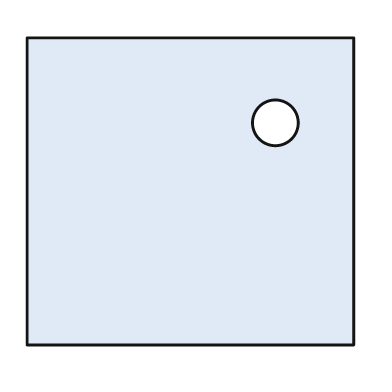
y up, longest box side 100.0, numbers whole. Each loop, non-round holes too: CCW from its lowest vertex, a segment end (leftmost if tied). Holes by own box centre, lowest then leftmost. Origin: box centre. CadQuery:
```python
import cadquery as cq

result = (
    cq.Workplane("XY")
    .moveTo(-50.0, -47.0)
    .lineTo(50.0, -47.0)
    .lineTo(50.0, 47.0)
    .lineTo(-50.0, 47.0)
    .close()
    .moveTo(26.0, 21.0)
    .circle(7.0)
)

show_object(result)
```